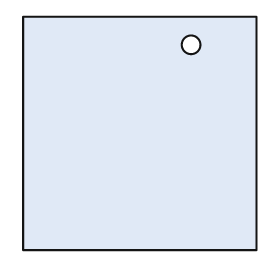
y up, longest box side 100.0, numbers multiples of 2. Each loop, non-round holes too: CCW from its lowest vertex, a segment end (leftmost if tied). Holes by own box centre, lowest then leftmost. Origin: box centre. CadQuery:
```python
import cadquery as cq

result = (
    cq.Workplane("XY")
    .moveTo(-50.0, -50.0)
    .lineTo(50.0, -50.0)
    .lineTo(50.0, 50.0)
    .lineTo(-50.0, 50.0)
    .close()
    .moveTo(22.0, 38.0)
    .circle(4.0)
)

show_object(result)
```